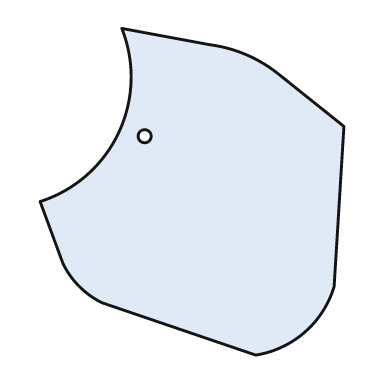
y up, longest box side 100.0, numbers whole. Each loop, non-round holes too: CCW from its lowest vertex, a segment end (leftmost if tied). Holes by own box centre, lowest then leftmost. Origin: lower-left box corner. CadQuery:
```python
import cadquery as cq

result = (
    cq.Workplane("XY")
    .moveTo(66.0, 0.0)
    .threePointArc((81.0, 7.0), (90.0, 21.0))
    .lineTo(93.0, 70.0)
    .lineTo(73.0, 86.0)
    .threePointArc((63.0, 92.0), (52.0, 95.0))
    .lineTo(25.0, 100.0)
    .threePointArc((24.0, 68.0), (0.0, 47.0))
    .lineTo(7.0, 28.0)
    .threePointArc((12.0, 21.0), (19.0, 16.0))
    .close()
    .moveTo(32.0, 67.0)
    .circle(2.0)
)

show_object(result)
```